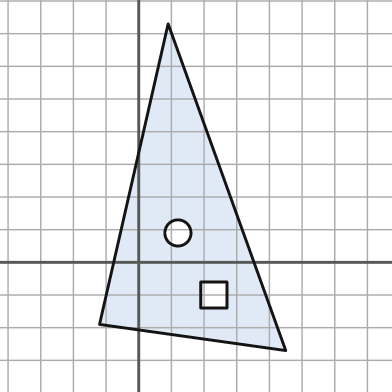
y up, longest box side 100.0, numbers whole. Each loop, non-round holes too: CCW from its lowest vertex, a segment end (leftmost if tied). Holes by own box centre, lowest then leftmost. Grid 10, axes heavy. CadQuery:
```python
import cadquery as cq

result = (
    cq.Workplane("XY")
    .moveTo(45.0, -27.0)
    .lineTo(9.0, 73.0)
    .lineTo(-12.0, -19.0)
    .close()
    .moveTo(19.0, -14.0)
    .lineTo(27.0, -14.0)
    .lineTo(27.0, -6.0)
    .lineTo(19.0, -6.0)
    .close()
    .moveTo(12.0, 9.0)
    .circle(4.0)
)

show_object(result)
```